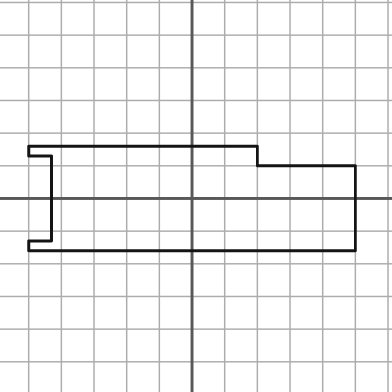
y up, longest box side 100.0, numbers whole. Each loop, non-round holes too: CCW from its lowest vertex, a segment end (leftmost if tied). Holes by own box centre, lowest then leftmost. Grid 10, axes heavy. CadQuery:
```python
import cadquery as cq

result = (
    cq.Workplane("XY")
    .moveTo(-50.0, -16.0)
    .lineTo(50.0, -16.0)
    .lineTo(50.0, 10.0)
    .lineTo(20.0, 10.0)
    .lineTo(20.0, 16.0)
    .lineTo(-50.0, 16.0)
    .lineTo(-50.0, 13.0)
    .lineTo(-43.0, 13.0)
    .lineTo(-43.0, -13.0)
    .lineTo(-50.0, -13.0)
    .close()
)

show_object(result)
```